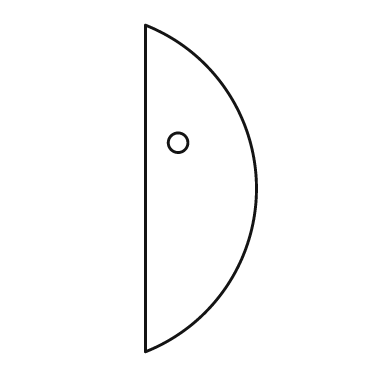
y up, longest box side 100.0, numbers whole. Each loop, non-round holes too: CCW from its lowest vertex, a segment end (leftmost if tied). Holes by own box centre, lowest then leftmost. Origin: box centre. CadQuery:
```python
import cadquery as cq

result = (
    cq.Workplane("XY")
    .moveTo(-17.0, -50.0)
    .threePointArc((17.0, 0.0), (-17.0, 50.0))
    .close()
    .moveTo(-7.0, 14.0)
    .circle(3.0)
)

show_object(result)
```